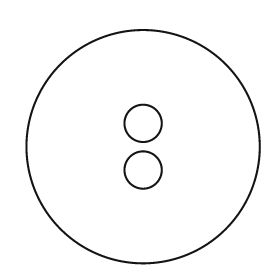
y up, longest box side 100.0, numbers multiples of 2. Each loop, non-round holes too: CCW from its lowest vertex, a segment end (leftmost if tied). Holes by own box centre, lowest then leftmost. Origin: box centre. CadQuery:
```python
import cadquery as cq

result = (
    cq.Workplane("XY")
    .moveTo(0.0, 0.0)
    .circle(50.0)
    .moveTo(0.0, -10.0)
    .circle(8.0)
    .moveTo(0.0, 10.0)
    .circle(8.0)
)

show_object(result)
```